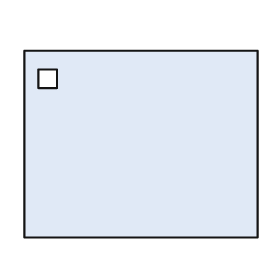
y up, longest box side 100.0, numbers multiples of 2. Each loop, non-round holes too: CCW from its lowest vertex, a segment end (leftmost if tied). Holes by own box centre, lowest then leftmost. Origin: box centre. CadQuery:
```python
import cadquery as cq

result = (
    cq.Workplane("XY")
    .moveTo(-50.0, -40.0)
    .lineTo(50.0, -40.0)
    .lineTo(50.0, 40.0)
    .lineTo(-50.0, 40.0)
    .close()
    .moveTo(-44.0, 24.0)
    .lineTo(-36.0, 24.0)
    .lineTo(-36.0, 32.0)
    .lineTo(-44.0, 32.0)
    .close()
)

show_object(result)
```